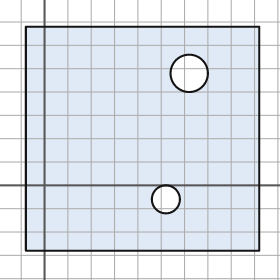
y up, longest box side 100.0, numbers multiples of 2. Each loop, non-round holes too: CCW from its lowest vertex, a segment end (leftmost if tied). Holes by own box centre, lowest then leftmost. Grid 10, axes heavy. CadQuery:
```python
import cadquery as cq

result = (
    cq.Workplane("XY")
    .moveTo(-8.0, -28.0)
    .lineTo(92.0, -28.0)
    .lineTo(92.0, 68.0)
    .lineTo(-8.0, 68.0)
    .close()
    .moveTo(52.0, -6.0)
    .circle(6.0)
    .moveTo(62.0, 48.0)
    .circle(8.0)
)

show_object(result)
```